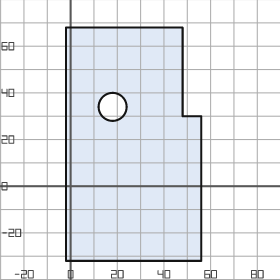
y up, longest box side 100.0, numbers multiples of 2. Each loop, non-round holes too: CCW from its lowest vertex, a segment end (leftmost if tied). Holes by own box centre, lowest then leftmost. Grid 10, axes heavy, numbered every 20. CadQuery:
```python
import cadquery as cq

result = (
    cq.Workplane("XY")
    .moveTo(-2.0, -32.0)
    .lineTo(56.0, -32.0)
    .lineTo(56.0, 30.0)
    .lineTo(48.0, 30.0)
    .lineTo(48.0, 68.0)
    .lineTo(-2.0, 68.0)
    .close()
    .moveTo(18.0, 34.0)
    .circle(6.0)
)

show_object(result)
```